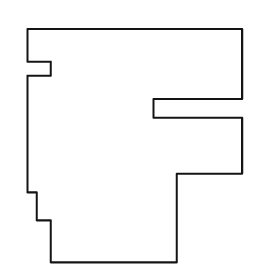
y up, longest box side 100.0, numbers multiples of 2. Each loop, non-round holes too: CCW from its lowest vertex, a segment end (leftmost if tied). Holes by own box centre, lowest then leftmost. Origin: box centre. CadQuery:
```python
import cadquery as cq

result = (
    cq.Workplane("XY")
    .moveTo(-36.0, -50.0)
    .lineTo(18.0, -50.0)
    .lineTo(18.0, -12.0)
    .lineTo(46.0, -12.0)
    .lineTo(46.0, 12.0)
    .lineTo(8.0, 12.0)
    .lineTo(8.0, 20.0)
    .lineTo(46.0, 20.0)
    .lineTo(46.0, 50.0)
    .lineTo(-46.0, 50.0)
    .lineTo(-46.0, 36.0)
    .lineTo(-36.0, 36.0)
    .lineTo(-36.0, 30.0)
    .lineTo(-46.0, 30.0)
    .lineTo(-46.0, -20.0)
    .lineTo(-42.0, -20.0)
    .lineTo(-42.0, -32.0)
    .lineTo(-36.0, -32.0)
    .close()
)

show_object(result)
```